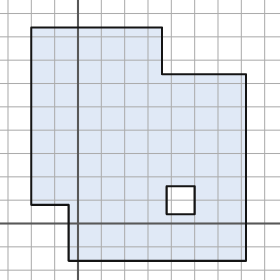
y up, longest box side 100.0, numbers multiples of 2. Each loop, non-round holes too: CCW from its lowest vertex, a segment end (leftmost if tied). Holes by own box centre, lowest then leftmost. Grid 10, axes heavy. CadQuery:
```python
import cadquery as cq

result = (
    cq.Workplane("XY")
    .moveTo(-4.0, -16.0)
    .lineTo(72.0, -16.0)
    .lineTo(72.0, 64.0)
    .lineTo(36.0, 64.0)
    .lineTo(36.0, 84.0)
    .lineTo(-20.0, 84.0)
    .lineTo(-20.0, 8.0)
    .lineTo(-4.0, 8.0)
    .close()
    .moveTo(38.0, 4.0)
    .lineTo(50.0, 4.0)
    .lineTo(50.0, 16.0)
    .lineTo(38.0, 16.0)
    .close()
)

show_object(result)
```